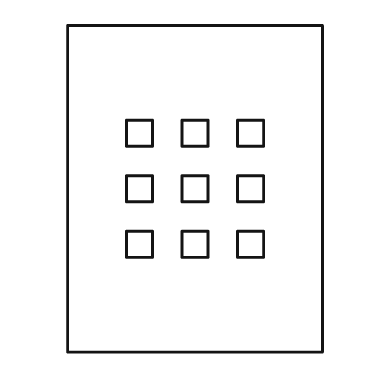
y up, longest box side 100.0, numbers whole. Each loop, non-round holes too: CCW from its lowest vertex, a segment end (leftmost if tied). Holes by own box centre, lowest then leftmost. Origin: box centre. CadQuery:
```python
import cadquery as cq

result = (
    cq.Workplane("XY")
    .moveTo(-39.0, -50.0)
    .lineTo(39.0, -50.0)
    .lineTo(39.0, 50.0)
    .lineTo(-39.0, 50.0)
    .close()
    .moveTo(-21.0, -21.0)
    .lineTo(-13.0, -21.0)
    .lineTo(-13.0, -13.0)
    .lineTo(-21.0, -13.0)
    .close()
    .moveTo(-4.0, -21.0)
    .lineTo(4.0, -21.0)
    .lineTo(4.0, -13.0)
    .lineTo(-4.0, -13.0)
    .close()
    .moveTo(13.0, -21.0)
    .lineTo(21.0, -21.0)
    .lineTo(21.0, -13.0)
    .lineTo(13.0, -13.0)
    .close()
    .moveTo(-21.0, -4.0)
    .lineTo(-13.0, -4.0)
    .lineTo(-13.0, 4.0)
    .lineTo(-21.0, 4.0)
    .close()
    .moveTo(-4.0, -4.0)
    .lineTo(4.0, -4.0)
    .lineTo(4.0, 4.0)
    .lineTo(-4.0, 4.0)
    .close()
    .moveTo(13.0, -4.0)
    .lineTo(21.0, -4.0)
    .lineTo(21.0, 4.0)
    .lineTo(13.0, 4.0)
    .close()
    .moveTo(-21.0, 13.0)
    .lineTo(-13.0, 13.0)
    .lineTo(-13.0, 21.0)
    .lineTo(-21.0, 21.0)
    .close()
    .moveTo(-4.0, 13.0)
    .lineTo(4.0, 13.0)
    .lineTo(4.0, 21.0)
    .lineTo(-4.0, 21.0)
    .close()
    .moveTo(13.0, 13.0)
    .lineTo(21.0, 13.0)
    .lineTo(21.0, 21.0)
    .lineTo(13.0, 21.0)
    .close()
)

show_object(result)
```